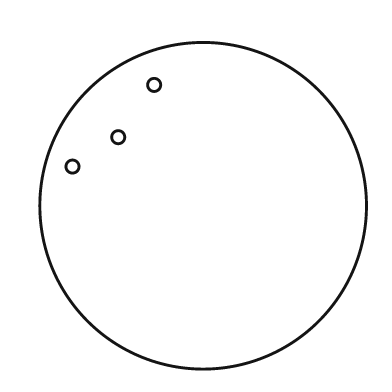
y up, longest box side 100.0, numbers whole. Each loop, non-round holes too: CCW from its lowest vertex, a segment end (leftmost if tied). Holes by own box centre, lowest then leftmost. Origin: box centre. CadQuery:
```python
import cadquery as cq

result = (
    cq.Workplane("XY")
    .moveTo(0.0, 0.0)
    .circle(50.0)
    .moveTo(-40.0, 12.0)
    .circle(2.0)
    .moveTo(-26.0, 21.0)
    .circle(2.0)
    .moveTo(-15.0, 37.0)
    .circle(2.0)
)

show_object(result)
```